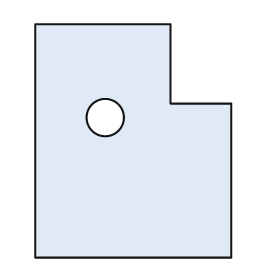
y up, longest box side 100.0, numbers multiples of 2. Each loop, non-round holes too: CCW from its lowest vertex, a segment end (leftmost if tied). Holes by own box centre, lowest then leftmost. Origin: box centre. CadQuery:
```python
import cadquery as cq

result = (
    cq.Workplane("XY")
    .moveTo(-42.0, -50.0)
    .lineTo(42.0, -50.0)
    .lineTo(42.0, 16.0)
    .lineTo(16.0, 16.0)
    .lineTo(16.0, 50.0)
    .lineTo(-42.0, 50.0)
    .close()
    .moveTo(-12.0, 10.0)
    .circle(8.0)
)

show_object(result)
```